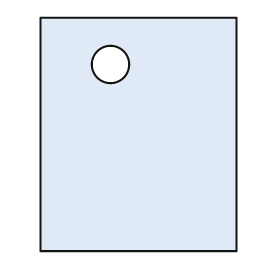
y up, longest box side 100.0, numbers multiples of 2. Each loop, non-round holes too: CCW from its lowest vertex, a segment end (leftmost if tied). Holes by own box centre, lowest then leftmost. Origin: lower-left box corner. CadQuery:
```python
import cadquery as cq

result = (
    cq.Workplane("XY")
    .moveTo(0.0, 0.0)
    .lineTo(84.0, 0.0)
    .lineTo(84.0, 100.0)
    .lineTo(0.0, 100.0)
    .close()
    .moveTo(30.0, 80.0)
    .circle(8.0)
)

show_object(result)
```